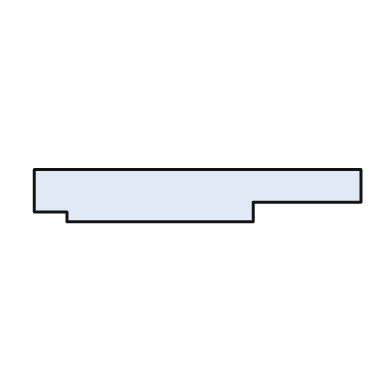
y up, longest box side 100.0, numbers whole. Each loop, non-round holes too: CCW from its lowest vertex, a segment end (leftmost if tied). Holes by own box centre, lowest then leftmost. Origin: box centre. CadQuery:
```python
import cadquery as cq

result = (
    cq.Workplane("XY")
    .moveTo(-40.0, -8.0)
    .lineTo(17.0, -8.0)
    .lineTo(17.0, -2.0)
    .lineTo(50.0, -2.0)
    .lineTo(50.0, 8.0)
    .lineTo(-50.0, 8.0)
    .lineTo(-50.0, -5.0)
    .lineTo(-40.0, -5.0)
    .close()
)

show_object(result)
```